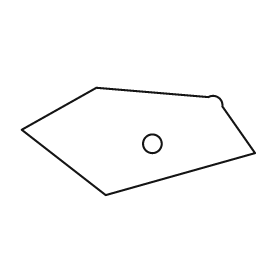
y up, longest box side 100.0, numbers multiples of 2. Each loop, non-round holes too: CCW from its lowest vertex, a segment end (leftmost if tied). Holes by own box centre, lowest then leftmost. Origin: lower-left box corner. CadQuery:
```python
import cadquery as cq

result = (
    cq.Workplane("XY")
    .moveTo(36.0, 0.0)
    .lineTo(100.0, 18.0)
    .lineTo(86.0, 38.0)
    .threePointArc((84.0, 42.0), (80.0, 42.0))
    .lineTo(32.0, 46.0)
    .lineTo(0.0, 28.0)
    .close()
    .moveTo(56.0, 22.0)
    .circle(4.0)
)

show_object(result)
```